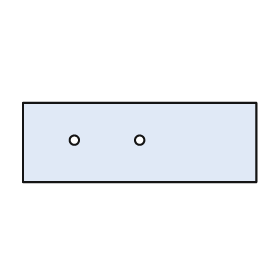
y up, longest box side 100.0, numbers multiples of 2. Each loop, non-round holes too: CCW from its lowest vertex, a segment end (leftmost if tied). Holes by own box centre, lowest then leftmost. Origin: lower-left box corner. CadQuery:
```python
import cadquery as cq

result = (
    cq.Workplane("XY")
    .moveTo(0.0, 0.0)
    .lineTo(100.0, 0.0)
    .lineTo(100.0, 34.0)
    .lineTo(0.0, 34.0)
    .close()
    .moveTo(22.0, 18.0)
    .circle(2.0)
    .moveTo(50.0, 18.0)
    .circle(2.0)
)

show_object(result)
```